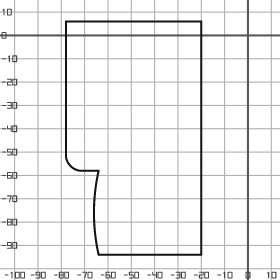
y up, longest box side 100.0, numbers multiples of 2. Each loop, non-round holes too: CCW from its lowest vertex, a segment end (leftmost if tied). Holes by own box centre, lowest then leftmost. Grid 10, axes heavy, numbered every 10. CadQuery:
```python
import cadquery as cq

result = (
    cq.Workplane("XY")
    .moveTo(-64.0, -94.0)
    .lineTo(-20.0, -94.0)
    .lineTo(-20.0, 6.0)
    .lineTo(-78.0, 6.0)
    .lineTo(-78.0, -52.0)
    .threePointArc((-76.0, -56.0), (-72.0, -58.0))
    .lineTo(-64.0, -58.0)
    .threePointArc((-66.0, -76.0), (-64.0, -94.0))
    .close()
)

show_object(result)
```